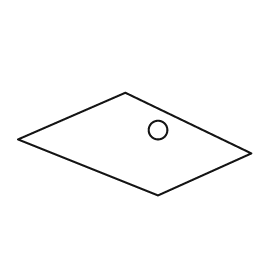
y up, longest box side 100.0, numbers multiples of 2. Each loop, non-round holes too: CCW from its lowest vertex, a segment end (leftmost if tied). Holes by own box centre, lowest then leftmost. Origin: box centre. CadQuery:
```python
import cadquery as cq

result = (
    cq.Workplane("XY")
    .moveTo(10.0, -22.0)
    .lineTo(50.0, -4.0)
    .lineTo(-4.0, 22.0)
    .lineTo(-50.0, 2.0)
    .close()
    .moveTo(10.0, 6.0)
    .circle(4.0)
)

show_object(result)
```